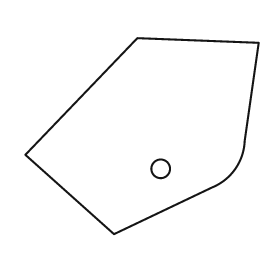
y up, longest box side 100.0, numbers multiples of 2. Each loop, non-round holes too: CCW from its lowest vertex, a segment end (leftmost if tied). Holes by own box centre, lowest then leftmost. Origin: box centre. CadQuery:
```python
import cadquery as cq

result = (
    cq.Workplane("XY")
    .moveTo(-12.0, -42.0)
    .lineTo(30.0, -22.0)
    .threePointArc((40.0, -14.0), (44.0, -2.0))
    .lineTo(50.0, 40.0)
    .lineTo(-2.0, 42.0)
    .lineTo(-50.0, -8.0)
    .close()
    .moveTo(8.0, -14.0)
    .circle(4.0)
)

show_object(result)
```